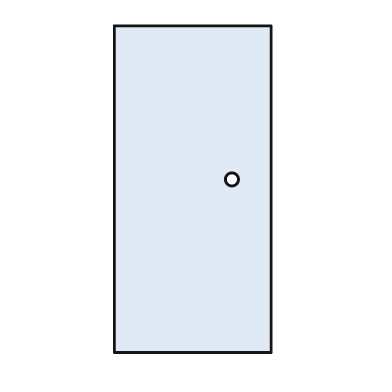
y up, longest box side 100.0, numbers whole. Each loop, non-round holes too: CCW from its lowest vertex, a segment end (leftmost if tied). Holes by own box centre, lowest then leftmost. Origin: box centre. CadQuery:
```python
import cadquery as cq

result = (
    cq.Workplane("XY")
    .moveTo(-24.0, -50.0)
    .lineTo(24.0, -50.0)
    .lineTo(24.0, 50.0)
    .lineTo(-24.0, 50.0)
    .close()
    .moveTo(12.0, 3.0)
    .circle(2.0)
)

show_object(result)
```